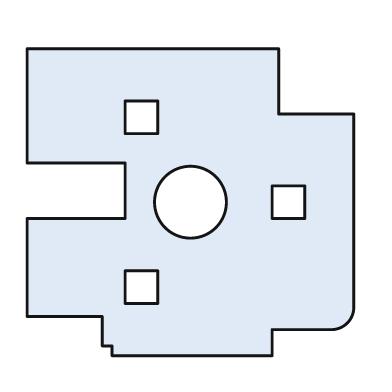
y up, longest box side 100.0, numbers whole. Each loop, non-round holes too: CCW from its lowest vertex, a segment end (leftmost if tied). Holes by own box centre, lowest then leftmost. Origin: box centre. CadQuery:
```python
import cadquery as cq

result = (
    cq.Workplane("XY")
    .moveTo(-24.0, -47.0)
    .lineTo(25.0, -47.0)
    .lineTo(25.0, -39.0)
    .lineTo(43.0, -39.0)
    .threePointArc((48.0, -37.0), (50.0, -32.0))
    .lineTo(50.0, 27.0)
    .lineTo(27.0, 27.0)
    .lineTo(27.0, 47.0)
    .lineTo(-50.0, 47.0)
    .lineTo(-50.0, 12.0)
    .lineTo(-20.0, 12.0)
    .lineTo(-20.0, -5.0)
    .lineTo(-50.0, -5.0)
    .lineTo(-50.0, -35.0)
    .lineTo(-27.0, -35.0)
    .lineTo(-27.0, -44.0)
    .lineTo(-24.0, -44.0)
    .close()
    .moveTo(-20.0, -31.0)
    .lineTo(-10.0, -31.0)
    .lineTo(-10.0, -21.0)
    .lineTo(-20.0, -21.0)
    .close()
    .moveTo(0.0, 0.0)
    .circle(11.0)
    .moveTo(25.0, -5.0)
    .lineTo(35.0, -5.0)
    .lineTo(35.0, 5.0)
    .lineTo(25.0, 5.0)
    .close()
    .moveTo(-20.0, 21.0)
    .lineTo(-10.0, 21.0)
    .lineTo(-10.0, 31.0)
    .lineTo(-20.0, 31.0)
    .close()
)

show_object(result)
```